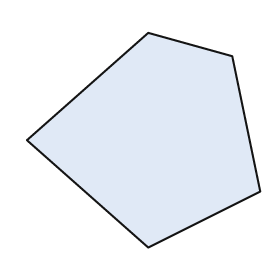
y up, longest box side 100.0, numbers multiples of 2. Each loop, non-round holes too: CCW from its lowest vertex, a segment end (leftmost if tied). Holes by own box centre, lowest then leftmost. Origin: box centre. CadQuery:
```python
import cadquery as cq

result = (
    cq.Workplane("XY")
    .moveTo(2.0, -46.0)
    .lineTo(50.0, -22.0)
    .lineTo(38.0, 36.0)
    .lineTo(2.0, 46.0)
    .lineTo(-50.0, 0.0)
    .close()
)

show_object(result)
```